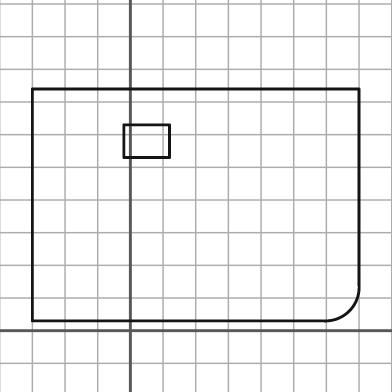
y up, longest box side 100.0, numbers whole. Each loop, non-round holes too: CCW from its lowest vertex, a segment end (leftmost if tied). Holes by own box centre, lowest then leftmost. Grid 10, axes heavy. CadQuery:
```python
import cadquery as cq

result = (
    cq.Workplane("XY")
    .moveTo(-30.0, 3.0)
    .lineTo(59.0, 3.0)
    .threePointArc((67.0, 6.0), (70.0, 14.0))
    .lineTo(70.0, 74.0)
    .lineTo(-30.0, 74.0)
    .close()
    .moveTo(-2.0, 53.0)
    .lineTo(12.0, 53.0)
    .lineTo(12.0, 63.0)
    .lineTo(-2.0, 63.0)
    .close()
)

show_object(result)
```